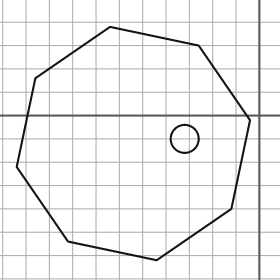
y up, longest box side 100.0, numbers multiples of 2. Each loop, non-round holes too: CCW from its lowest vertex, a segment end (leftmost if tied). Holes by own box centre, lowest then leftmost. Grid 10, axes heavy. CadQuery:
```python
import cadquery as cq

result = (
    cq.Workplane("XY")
    .moveTo(-44.0, -62.0)
    .lineTo(-12.0, -40.0)
    .lineTo(-4.0, -2.0)
    .lineTo(-26.0, 30.0)
    .lineTo(-64.0, 38.0)
    .lineTo(-96.0, 16.0)
    .lineTo(-104.0, -22.0)
    .lineTo(-82.0, -54.0)
    .close()
    .moveTo(-32.0, -10.0)
    .circle(6.0)
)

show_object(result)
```